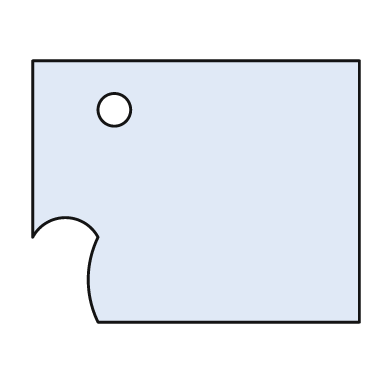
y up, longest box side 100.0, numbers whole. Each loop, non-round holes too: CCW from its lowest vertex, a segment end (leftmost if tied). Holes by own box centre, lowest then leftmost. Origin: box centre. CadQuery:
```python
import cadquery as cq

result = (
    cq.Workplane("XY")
    .moveTo(-30.0, -40.0)
    .lineTo(50.0, -40.0)
    .lineTo(50.0, 40.0)
    .lineTo(-50.0, 40.0)
    .lineTo(-50.0, -14.0)
    .threePointArc((-40.0, -8.0), (-30.0, -14.0))
    .threePointArc((-33.0, -27.0), (-30.0, -40.0))
    .close()
    .moveTo(-25.0, 25.0)
    .circle(5.0)
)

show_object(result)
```